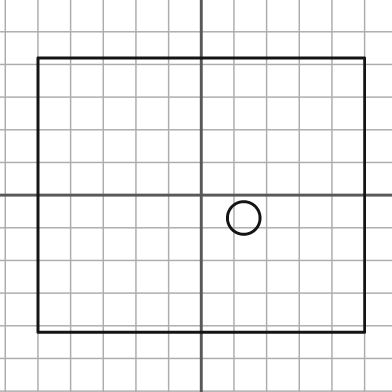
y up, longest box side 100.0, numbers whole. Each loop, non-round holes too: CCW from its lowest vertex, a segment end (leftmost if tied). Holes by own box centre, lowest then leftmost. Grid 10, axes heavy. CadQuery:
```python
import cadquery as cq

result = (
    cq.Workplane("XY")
    .moveTo(-50.0, -42.0)
    .lineTo(50.0, -42.0)
    .lineTo(50.0, 42.0)
    .lineTo(-50.0, 42.0)
    .close()
    .moveTo(13.0, -7.0)
    .circle(5.0)
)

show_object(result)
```